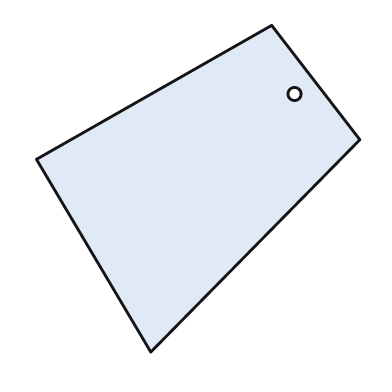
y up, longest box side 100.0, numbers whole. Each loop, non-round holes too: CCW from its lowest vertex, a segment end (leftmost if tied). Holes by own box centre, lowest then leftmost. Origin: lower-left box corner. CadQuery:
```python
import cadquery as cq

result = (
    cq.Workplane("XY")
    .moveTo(35.0, 0.0)
    .lineTo(99.0, 65.0)
    .lineTo(72.0, 100.0)
    .lineTo(0.0, 59.0)
    .close()
    .moveTo(79.0, 79.0)
    .circle(2.0)
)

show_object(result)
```